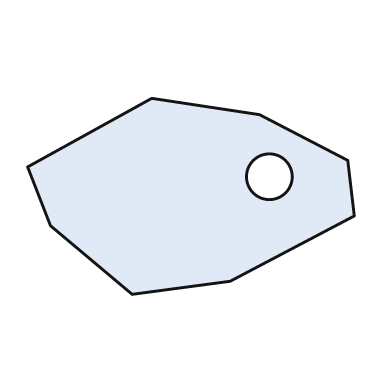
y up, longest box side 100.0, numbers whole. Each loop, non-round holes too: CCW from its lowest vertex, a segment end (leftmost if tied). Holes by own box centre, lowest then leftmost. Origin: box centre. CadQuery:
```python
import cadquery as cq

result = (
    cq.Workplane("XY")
    .moveTo(-18.0, -30.0)
    .lineTo(12.0, -26.0)
    .lineTo(50.0, -6.0)
    .lineTo(48.0, 11.0)
    .lineTo(21.0, 25.0)
    .lineTo(-12.0, 30.0)
    .lineTo(-50.0, 9.0)
    .lineTo(-43.0, -9.0)
    .close()
    .moveTo(24.0, 6.0)
    .circle(7.0)
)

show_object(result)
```